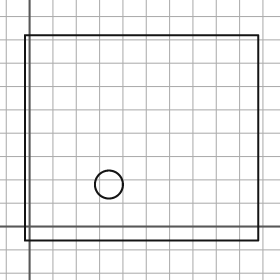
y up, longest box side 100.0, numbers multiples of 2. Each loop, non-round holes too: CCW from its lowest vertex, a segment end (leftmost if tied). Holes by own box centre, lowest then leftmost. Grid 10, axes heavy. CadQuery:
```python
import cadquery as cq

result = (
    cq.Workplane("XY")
    .moveTo(-2.0, -6.0)
    .lineTo(98.0, -6.0)
    .lineTo(98.0, 82.0)
    .lineTo(-2.0, 82.0)
    .close()
    .moveTo(34.0, 18.0)
    .circle(6.0)
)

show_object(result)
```